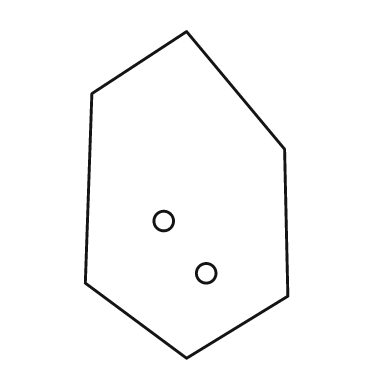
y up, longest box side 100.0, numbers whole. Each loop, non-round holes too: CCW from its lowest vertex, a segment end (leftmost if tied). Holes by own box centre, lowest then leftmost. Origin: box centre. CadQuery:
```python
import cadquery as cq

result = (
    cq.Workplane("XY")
    .moveTo(0.0, -50.0)
    .lineTo(31.0, -31.0)
    .lineTo(30.0, 14.0)
    .lineTo(0.0, 50.0)
    .lineTo(-29.0, 31.0)
    .lineTo(-31.0, -27.0)
    .close()
    .moveTo(6.0, -24.0)
    .circle(3.0)
    .moveTo(-7.0, -8.0)
    .circle(3.0)
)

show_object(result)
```